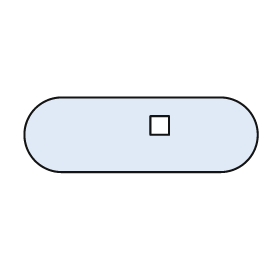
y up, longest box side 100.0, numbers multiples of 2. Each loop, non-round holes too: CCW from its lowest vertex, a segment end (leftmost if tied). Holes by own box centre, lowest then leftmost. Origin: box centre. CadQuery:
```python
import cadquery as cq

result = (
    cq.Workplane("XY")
    .moveTo(-34.0, -16.0)
    .lineTo(34.0, -16.0)
    .threePointArc((50.0, 0.0), (34.0, 16.0))
    .lineTo(-34.0, 16.0)
    .threePointArc((-50.0, 0.0), (-34.0, -16.0))
    .close()
    .moveTo(4.0, 0.0)
    .lineTo(12.0, 0.0)
    .lineTo(12.0, 8.0)
    .lineTo(4.0, 8.0)
    .close()
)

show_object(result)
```